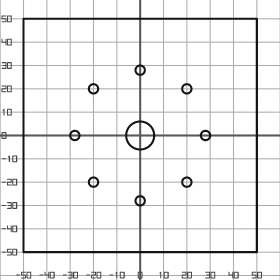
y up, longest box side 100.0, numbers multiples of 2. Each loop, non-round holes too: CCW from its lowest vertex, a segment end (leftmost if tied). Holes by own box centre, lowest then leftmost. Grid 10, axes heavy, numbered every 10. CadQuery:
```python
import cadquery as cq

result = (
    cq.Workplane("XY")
    .moveTo(-50.0, -50.0)
    .lineTo(50.0, -50.0)
    .lineTo(50.0, 50.0)
    .lineTo(-50.0, 50.0)
    .close()
    .moveTo(0.0, -28.0)
    .circle(2.0)
    .moveTo(-20.0, -20.0)
    .circle(2.0)
    .moveTo(20.0, -20.0)
    .circle(2.0)
    .moveTo(-28.0, 0.0)
    .circle(2.0)
    .moveTo(0.0, 0.0)
    .circle(6.0)
    .moveTo(28.0, 0.0)
    .circle(2.0)
    .moveTo(-20.0, 20.0)
    .circle(2.0)
    .moveTo(20.0, 20.0)
    .circle(2.0)
    .moveTo(0.0, 28.0)
    .circle(2.0)
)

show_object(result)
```